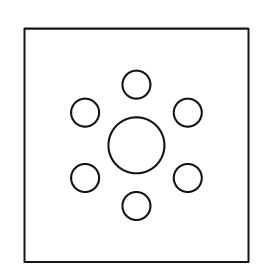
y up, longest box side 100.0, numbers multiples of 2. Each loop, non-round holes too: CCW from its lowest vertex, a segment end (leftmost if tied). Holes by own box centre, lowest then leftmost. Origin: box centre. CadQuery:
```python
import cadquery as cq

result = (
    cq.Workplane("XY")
    .moveTo(-48.0, -50.0)
    .lineTo(48.0, -50.0)
    .lineTo(48.0, 50.0)
    .lineTo(-48.0, 50.0)
    .close()
    .moveTo(0.0, -26.0)
    .circle(6.0)
    .moveTo(-22.0, -14.0)
    .circle(6.0)
    .moveTo(22.0, -14.0)
    .circle(6.0)
    .moveTo(0.0, 0.0)
    .circle(12.0)
    .moveTo(-22.0, 14.0)
    .circle(6.0)
    .moveTo(22.0, 14.0)
    .circle(6.0)
    .moveTo(0.0, 26.0)
    .circle(6.0)
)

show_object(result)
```